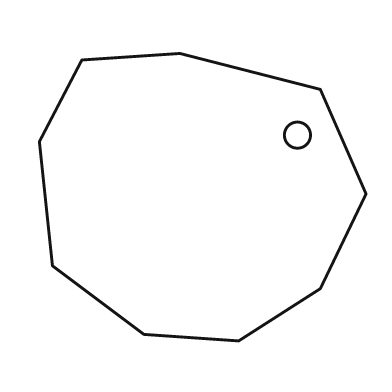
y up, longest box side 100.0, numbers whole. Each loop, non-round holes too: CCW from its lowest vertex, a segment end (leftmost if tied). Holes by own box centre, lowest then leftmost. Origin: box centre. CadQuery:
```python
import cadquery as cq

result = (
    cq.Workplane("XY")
    .moveTo(11.0, -44.0)
    .lineTo(36.0, -28.0)
    .lineTo(50.0, 1.0)
    .lineTo(36.0, 33.0)
    .lineTo(-7.0, 44.0)
    .lineTo(-37.0, 42.0)
    .lineTo(-50.0, 17.0)
    .lineTo(-46.0, -21.0)
    .lineTo(-18.0, -42.0)
    .close()
    .moveTo(29.0, 19.0)
    .circle(4.0)
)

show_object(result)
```